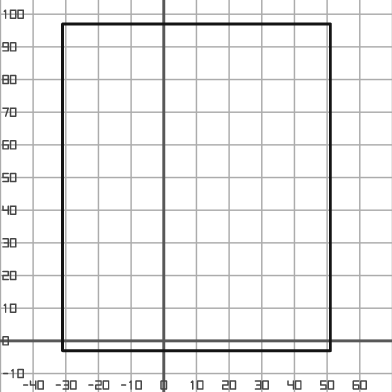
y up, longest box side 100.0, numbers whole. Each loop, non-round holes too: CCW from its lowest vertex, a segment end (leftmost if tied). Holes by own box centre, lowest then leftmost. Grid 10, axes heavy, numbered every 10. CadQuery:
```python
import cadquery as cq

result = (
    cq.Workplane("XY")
    .moveTo(-31.0, -3.0)
    .lineTo(51.0, -3.0)
    .lineTo(51.0, 97.0)
    .lineTo(-31.0, 97.0)
    .close()
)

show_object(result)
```